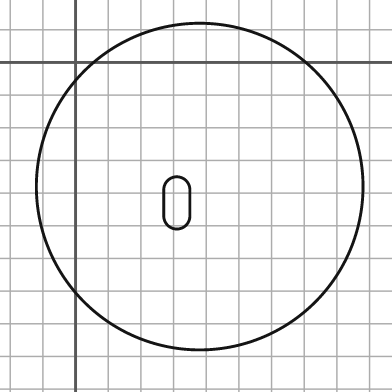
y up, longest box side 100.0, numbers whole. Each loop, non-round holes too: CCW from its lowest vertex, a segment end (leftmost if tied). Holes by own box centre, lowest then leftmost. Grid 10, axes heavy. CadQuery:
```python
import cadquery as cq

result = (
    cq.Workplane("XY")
    .moveTo(38.0, -38.0)
    .circle(50.0)
    .moveTo(27.0, -47.0)
    .threePointArc((31.0, -51.0), (35.0, -47.0))
    .lineTo(35.0, -39.0)
    .threePointArc((31.0, -35.0), (27.0, -39.0))
    .close()
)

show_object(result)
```